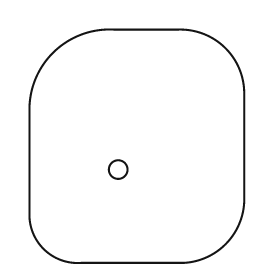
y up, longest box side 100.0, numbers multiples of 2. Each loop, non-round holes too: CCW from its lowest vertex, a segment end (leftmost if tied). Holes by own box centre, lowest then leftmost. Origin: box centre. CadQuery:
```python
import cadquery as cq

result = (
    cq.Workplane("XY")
    .moveTo(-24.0, -50.0)
    .lineTo(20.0, -50.0)
    .threePointArc((38.0, -42.0), (46.0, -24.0))
    .lineTo(46.0, 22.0)
    .threePointArc((38.0, 42.0), (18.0, 50.0))
    .lineTo(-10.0, 50.0)
    .threePointArc((-36.0, 40.0), (-46.0, 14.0))
    .lineTo(-46.0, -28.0)
    .threePointArc((-40.0, -44.0), (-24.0, -50.0))
    .close()
    .moveTo(-8.0, -10.0)
    .circle(4.0)
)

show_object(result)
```